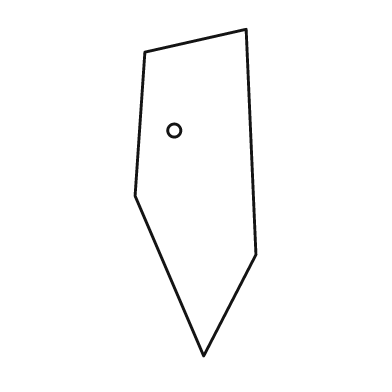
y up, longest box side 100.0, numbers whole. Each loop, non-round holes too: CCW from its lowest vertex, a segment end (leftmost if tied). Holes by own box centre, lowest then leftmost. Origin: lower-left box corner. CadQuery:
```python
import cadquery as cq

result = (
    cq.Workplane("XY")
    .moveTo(21.0, 0.0)
    .lineTo(37.0, 31.0)
    .lineTo(34.0, 100.0)
    .lineTo(3.0, 93.0)
    .lineTo(0.0, 49.0)
    .close()
    .moveTo(12.0, 69.0)
    .circle(2.0)
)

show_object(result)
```